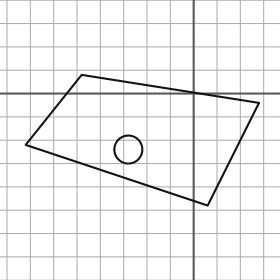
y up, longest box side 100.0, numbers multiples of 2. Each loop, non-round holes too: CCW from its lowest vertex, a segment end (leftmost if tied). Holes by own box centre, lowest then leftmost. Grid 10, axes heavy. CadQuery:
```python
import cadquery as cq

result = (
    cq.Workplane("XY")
    .moveTo(6.0, -48.0)
    .lineTo(28.0, -4.0)
    .lineTo(-48.0, 8.0)
    .lineTo(-72.0, -22.0)
    .close()
    .moveTo(-28.0, -24.0)
    .circle(6.0)
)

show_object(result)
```